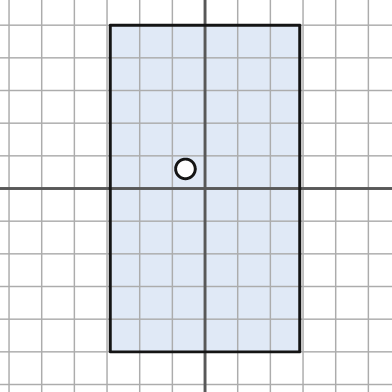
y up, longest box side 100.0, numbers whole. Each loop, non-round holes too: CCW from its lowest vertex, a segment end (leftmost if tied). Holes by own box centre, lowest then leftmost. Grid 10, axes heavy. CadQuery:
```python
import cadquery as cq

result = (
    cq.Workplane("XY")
    .moveTo(-29.0, -50.0)
    .lineTo(29.0, -50.0)
    .lineTo(29.0, 50.0)
    .lineTo(-29.0, 50.0)
    .close()
    .moveTo(-6.0, 6.0)
    .circle(3.0)
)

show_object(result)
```